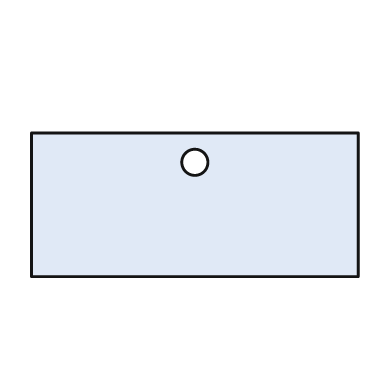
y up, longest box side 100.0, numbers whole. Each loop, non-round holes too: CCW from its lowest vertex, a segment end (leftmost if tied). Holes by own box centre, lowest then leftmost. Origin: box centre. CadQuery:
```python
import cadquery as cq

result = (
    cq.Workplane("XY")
    .moveTo(-50.0, -22.0)
    .lineTo(50.0, -22.0)
    .lineTo(50.0, 22.0)
    .lineTo(-50.0, 22.0)
    .close()
    .moveTo(0.0, 13.0)
    .circle(4.0)
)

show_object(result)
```